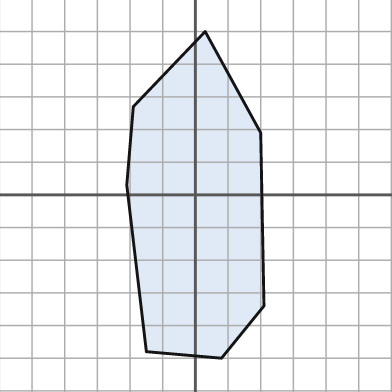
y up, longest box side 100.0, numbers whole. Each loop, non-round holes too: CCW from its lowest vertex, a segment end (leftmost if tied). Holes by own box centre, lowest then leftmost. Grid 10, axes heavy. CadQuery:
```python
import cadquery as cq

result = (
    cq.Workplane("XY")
    .moveTo(8.0, -50.0)
    .lineTo(21.0, -34.0)
    .lineTo(20.0, 19.0)
    .lineTo(3.0, 50.0)
    .lineTo(-19.0, 27.0)
    .lineTo(-21.0, 3.0)
    .lineTo(-15.0, -48.0)
    .close()
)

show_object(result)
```